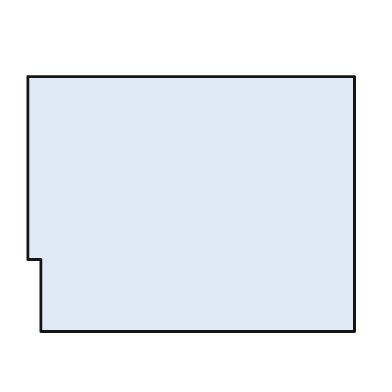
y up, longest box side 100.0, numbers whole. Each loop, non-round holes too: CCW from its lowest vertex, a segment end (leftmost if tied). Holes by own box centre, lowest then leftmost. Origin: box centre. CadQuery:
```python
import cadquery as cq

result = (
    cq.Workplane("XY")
    .moveTo(-46.0, -39.0)
    .lineTo(50.0, -39.0)
    .lineTo(50.0, 39.0)
    .lineTo(-50.0, 39.0)
    .lineTo(-50.0, -17.0)
    .lineTo(-46.0, -17.0)
    .close()
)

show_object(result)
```